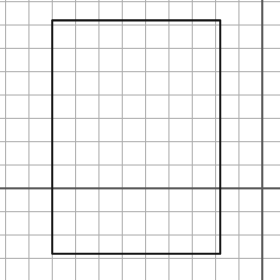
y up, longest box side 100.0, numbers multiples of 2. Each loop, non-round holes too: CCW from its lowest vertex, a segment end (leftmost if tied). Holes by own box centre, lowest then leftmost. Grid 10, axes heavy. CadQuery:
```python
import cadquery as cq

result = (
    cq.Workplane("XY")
    .moveTo(-90.0, -28.0)
    .lineTo(-18.0, -28.0)
    .lineTo(-18.0, 72.0)
    .lineTo(-90.0, 72.0)
    .close()
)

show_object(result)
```